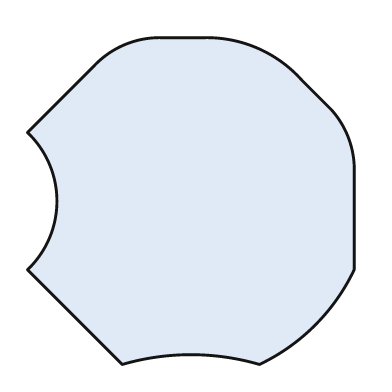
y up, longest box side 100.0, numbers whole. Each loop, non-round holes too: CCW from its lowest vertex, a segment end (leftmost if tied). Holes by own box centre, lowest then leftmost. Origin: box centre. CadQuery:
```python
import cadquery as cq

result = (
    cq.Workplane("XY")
    .moveTo(-21.0, -50.0)
    .threePointArc((0.0, -47.0), (21.0, -50.0))
    .threePointArc((38.0, -38.0), (50.0, -21.0))
    .lineTo(50.0, 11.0)
    .threePointArc((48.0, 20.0), (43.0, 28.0))
    .lineTo(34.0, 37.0)
    .threePointArc((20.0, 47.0), (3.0, 50.0))
    .lineTo(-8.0, 50.0)
    .threePointArc((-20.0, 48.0), (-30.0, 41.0))
    .lineTo(-50.0, 21.0)
    .threePointArc((-41.0, 0.0), (-50.0, -21.0))
    .close()
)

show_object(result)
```